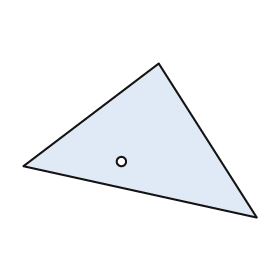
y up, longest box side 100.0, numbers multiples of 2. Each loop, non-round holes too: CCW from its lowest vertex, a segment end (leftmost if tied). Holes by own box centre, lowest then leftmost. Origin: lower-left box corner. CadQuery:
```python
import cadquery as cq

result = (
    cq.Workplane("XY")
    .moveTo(100.0, 0.0)
    .lineTo(58.0, 66.0)
    .lineTo(0.0, 22.0)
    .close()
    .moveTo(42.0, 24.0)
    .circle(2.0)
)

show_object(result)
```